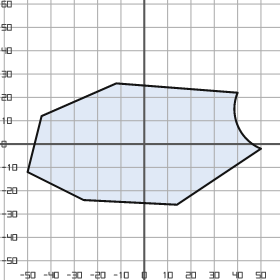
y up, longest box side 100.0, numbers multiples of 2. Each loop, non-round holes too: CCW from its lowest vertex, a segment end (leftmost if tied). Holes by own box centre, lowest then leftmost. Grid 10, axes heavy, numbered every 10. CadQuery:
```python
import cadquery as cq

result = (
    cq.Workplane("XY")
    .moveTo(14.0, -26.0)
    .lineTo(50.0, -2.0)
    .threePointArc((40.0, 8.0), (40.0, 22.0))
    .lineTo(-12.0, 26.0)
    .lineTo(-44.0, 12.0)
    .lineTo(-50.0, -12.0)
    .lineTo(-26.0, -24.0)
    .close()
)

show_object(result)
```